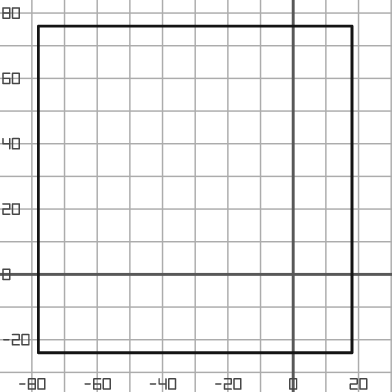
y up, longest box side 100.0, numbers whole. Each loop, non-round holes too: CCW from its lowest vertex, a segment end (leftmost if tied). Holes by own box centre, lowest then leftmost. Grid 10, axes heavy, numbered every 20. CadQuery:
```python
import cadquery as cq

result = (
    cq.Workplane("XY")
    .moveTo(-78.0, -24.0)
    .lineTo(18.0, -24.0)
    .lineTo(18.0, 76.0)
    .lineTo(-78.0, 76.0)
    .close()
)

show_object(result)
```